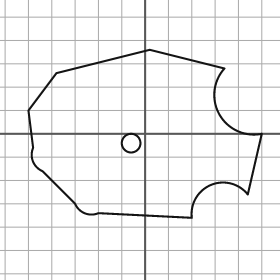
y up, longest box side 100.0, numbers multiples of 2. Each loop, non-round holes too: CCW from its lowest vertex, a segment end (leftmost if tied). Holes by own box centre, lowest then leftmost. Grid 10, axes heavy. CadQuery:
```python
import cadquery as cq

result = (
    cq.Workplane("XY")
    .moveTo(20.0, -36.0)
    .threePointArc((28.0, -22.0), (44.0, -26.0))
    .lineTo(50.0, 0.0)
    .threePointArc((32.0, 8.0), (34.0, 28.0))
    .lineTo(2.0, 36.0)
    .lineTo(-38.0, 26.0)
    .lineTo(-50.0, 10.0)
    .lineTo(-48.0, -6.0)
    .threePointArc((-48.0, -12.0), (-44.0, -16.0))
    .lineTo(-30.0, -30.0)
    .threePointArc((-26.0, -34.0), (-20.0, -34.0))
    .close()
    .moveTo(-6.0, -4.0)
    .circle(4.0)
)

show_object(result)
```